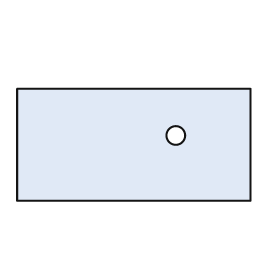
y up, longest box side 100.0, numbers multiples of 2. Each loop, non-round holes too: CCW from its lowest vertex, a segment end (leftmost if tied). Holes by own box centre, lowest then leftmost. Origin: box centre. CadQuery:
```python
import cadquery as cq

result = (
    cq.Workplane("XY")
    .moveTo(-50.0, -24.0)
    .lineTo(50.0, -24.0)
    .lineTo(50.0, 24.0)
    .lineTo(-50.0, 24.0)
    .close()
    .moveTo(18.0, 4.0)
    .circle(4.0)
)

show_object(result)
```